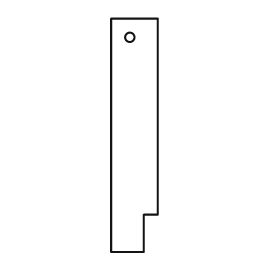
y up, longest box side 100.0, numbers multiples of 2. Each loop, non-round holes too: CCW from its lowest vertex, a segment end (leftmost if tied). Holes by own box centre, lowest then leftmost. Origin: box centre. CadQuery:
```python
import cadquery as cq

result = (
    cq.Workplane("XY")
    .moveTo(-10.0, -50.0)
    .lineTo(4.0, -50.0)
    .lineTo(4.0, -34.0)
    .lineTo(10.0, -34.0)
    .lineTo(10.0, 50.0)
    .lineTo(-10.0, 50.0)
    .close()
    .moveTo(-2.0, 42.0)
    .circle(2.0)
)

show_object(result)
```